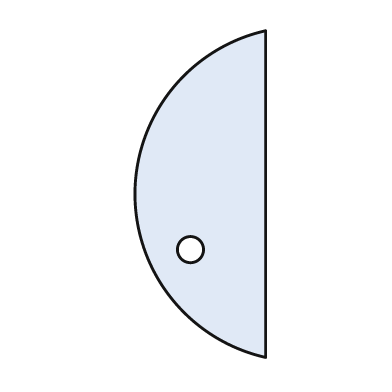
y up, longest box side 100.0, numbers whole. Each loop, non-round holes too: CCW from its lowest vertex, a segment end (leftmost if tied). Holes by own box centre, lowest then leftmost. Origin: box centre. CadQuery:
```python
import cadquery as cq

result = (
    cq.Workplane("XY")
    .moveTo(20.0, -50.0)
    .lineTo(20.0, 50.0)
    .threePointArc((-20.0, 0.0), (20.0, -50.0))
    .close()
    .moveTo(-3.0, -17.0)
    .circle(4.0)
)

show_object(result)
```